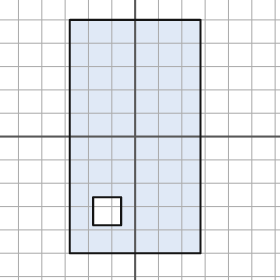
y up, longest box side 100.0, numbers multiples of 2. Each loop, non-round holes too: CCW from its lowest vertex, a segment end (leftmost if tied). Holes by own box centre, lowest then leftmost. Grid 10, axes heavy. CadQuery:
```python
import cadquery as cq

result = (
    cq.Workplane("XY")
    .moveTo(-28.0, -50.0)
    .lineTo(28.0, -50.0)
    .lineTo(28.0, 50.0)
    .lineTo(-28.0, 50.0)
    .close()
    .moveTo(-18.0, -38.0)
    .lineTo(-6.0, -38.0)
    .lineTo(-6.0, -26.0)
    .lineTo(-18.0, -26.0)
    .close()
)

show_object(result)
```